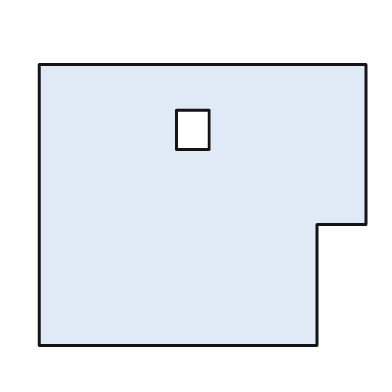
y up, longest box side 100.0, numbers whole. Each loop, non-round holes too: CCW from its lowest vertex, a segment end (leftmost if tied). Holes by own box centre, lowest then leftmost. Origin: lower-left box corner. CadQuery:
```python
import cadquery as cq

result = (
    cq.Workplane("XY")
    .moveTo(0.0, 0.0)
    .lineTo(85.0, 0.0)
    .lineTo(85.0, 37.0)
    .lineTo(100.0, 37.0)
    .lineTo(100.0, 86.0)
    .lineTo(0.0, 86.0)
    .close()
    .moveTo(42.0, 60.0)
    .lineTo(52.0, 60.0)
    .lineTo(52.0, 72.0)
    .lineTo(42.0, 72.0)
    .close()
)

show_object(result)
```